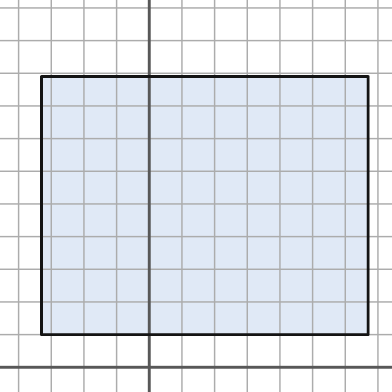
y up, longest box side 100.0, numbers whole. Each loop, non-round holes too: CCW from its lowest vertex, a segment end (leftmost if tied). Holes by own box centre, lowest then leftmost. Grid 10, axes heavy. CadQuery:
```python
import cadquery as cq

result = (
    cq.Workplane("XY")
    .moveTo(-33.0, 10.0)
    .lineTo(67.0, 10.0)
    .lineTo(67.0, 89.0)
    .lineTo(-33.0, 89.0)
    .close()
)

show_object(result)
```